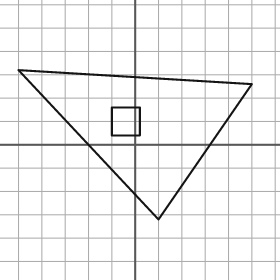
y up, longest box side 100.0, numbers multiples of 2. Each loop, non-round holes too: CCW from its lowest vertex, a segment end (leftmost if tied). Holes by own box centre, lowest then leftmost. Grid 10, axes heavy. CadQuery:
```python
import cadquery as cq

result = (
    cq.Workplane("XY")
    .moveTo(10.0, -32.0)
    .lineTo(50.0, 26.0)
    .lineTo(-50.0, 32.0)
    .close()
    .moveTo(-10.0, 4.0)
    .lineTo(2.0, 4.0)
    .lineTo(2.0, 16.0)
    .lineTo(-10.0, 16.0)
    .close()
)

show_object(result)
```